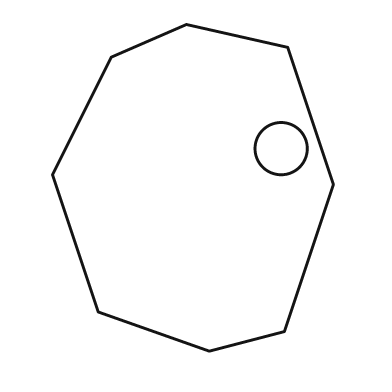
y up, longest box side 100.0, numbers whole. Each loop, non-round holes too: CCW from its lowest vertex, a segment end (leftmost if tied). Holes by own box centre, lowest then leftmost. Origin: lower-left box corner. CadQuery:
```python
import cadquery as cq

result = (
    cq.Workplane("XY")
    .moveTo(48.0, 0.0)
    .lineTo(71.0, 6.0)
    .lineTo(86.0, 51.0)
    .lineTo(72.0, 93.0)
    .lineTo(41.0, 100.0)
    .lineTo(18.0, 90.0)
    .lineTo(0.0, 54.0)
    .lineTo(14.0, 12.0)
    .close()
    .moveTo(70.0, 62.0)
    .circle(8.0)
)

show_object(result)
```